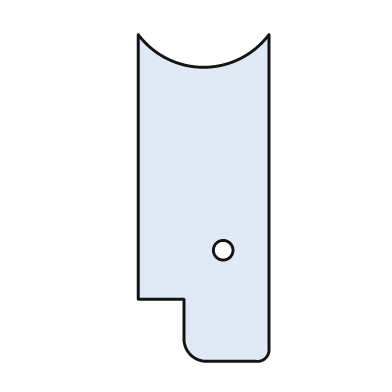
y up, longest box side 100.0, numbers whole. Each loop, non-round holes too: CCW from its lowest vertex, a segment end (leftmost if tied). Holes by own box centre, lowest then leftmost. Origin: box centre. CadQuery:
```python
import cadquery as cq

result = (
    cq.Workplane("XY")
    .moveTo(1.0, -50.0)
    .lineTo(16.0, -50.0)
    .threePointArc((19.0, -49.0), (20.0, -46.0))
    .lineTo(20.0, 50.0)
    .threePointArc((0.0, 40.0), (-20.0, 50.0))
    .lineTo(-20.0, -31.0)
    .lineTo(-6.0, -31.0)
    .lineTo(-6.0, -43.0)
    .threePointArc((-4.0, -48.0), (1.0, -50.0))
    .close()
    .moveTo(6.0, -16.0)
    .circle(3.0)
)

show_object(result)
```